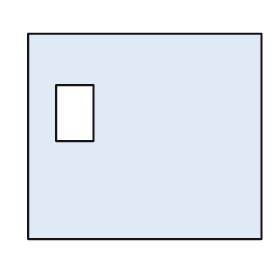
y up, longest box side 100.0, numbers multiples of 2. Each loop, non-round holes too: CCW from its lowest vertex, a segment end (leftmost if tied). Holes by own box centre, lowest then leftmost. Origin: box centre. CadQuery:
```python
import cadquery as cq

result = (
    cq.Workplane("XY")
    .moveTo(-50.0, -44.0)
    .lineTo(50.0, -44.0)
    .lineTo(50.0, 44.0)
    .lineTo(-50.0, 44.0)
    .close()
    .moveTo(-38.0, -2.0)
    .lineTo(-22.0, -2.0)
    .lineTo(-22.0, 22.0)
    .lineTo(-38.0, 22.0)
    .close()
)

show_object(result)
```